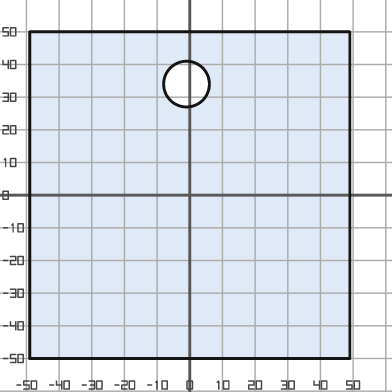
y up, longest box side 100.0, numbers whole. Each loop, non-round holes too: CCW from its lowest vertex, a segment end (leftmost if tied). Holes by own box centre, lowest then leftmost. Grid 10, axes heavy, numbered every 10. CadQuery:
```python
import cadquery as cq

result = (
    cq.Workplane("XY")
    .moveTo(-49.0, -50.0)
    .lineTo(49.0, -50.0)
    .lineTo(49.0, 50.0)
    .lineTo(-49.0, 50.0)
    .close()
    .moveTo(-1.0, 34.0)
    .circle(7.0)
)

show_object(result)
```